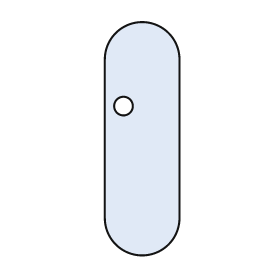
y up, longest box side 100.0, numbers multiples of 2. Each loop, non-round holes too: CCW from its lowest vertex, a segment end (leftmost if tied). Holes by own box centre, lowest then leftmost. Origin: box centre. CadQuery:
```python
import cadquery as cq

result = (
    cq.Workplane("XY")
    .moveTo(-16.0, -34.0)
    .threePointArc((0.0, -50.0), (16.0, -34.0))
    .lineTo(16.0, 34.0)
    .threePointArc((0.0, 50.0), (-16.0, 34.0))
    .close()
    .moveTo(-8.0, 14.0)
    .circle(4.0)
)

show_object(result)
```